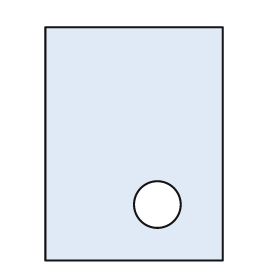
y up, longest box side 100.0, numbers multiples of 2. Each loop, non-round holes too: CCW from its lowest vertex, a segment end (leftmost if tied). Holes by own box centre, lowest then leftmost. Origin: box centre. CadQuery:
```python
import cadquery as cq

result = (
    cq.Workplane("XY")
    .moveTo(-38.0, -50.0)
    .lineTo(38.0, -50.0)
    .lineTo(38.0, 50.0)
    .lineTo(-38.0, 50.0)
    .close()
    .moveTo(10.0, -26.0)
    .circle(10.0)
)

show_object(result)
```